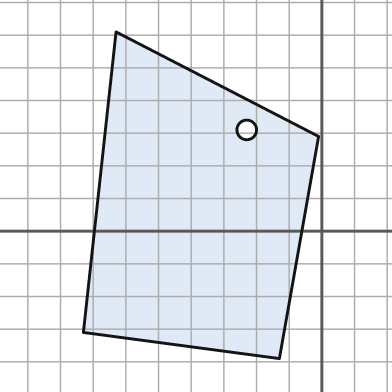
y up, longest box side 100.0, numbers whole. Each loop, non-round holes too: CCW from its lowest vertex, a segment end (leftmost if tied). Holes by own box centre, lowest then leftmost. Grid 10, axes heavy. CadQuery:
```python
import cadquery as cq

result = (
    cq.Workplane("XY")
    .moveTo(-13.0, -39.0)
    .lineTo(-1.0, 29.0)
    .lineTo(-63.0, 61.0)
    .lineTo(-73.0, -31.0)
    .close()
    .moveTo(-23.0, 31.0)
    .circle(3.0)
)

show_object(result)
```